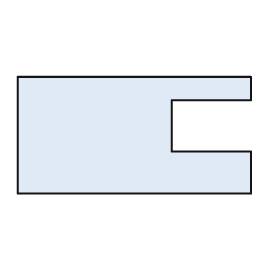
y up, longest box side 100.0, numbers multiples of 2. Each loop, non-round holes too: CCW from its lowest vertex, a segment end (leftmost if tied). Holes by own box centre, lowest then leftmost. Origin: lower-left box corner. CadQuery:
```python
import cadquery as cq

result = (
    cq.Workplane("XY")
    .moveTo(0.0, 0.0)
    .lineTo(100.0, 0.0)
    .lineTo(100.0, 18.0)
    .lineTo(66.0, 18.0)
    .lineTo(66.0, 40.0)
    .lineTo(100.0, 40.0)
    .lineTo(100.0, 50.0)
    .lineTo(0.0, 50.0)
    .close()
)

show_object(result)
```